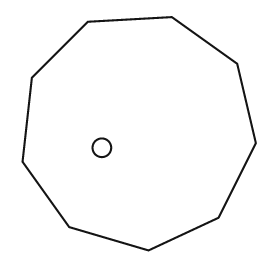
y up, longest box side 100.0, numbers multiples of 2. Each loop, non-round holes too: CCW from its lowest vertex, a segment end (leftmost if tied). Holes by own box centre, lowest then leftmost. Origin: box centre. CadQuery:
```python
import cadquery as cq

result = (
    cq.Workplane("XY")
    .moveTo(4.0, -50.0)
    .lineTo(34.0, -36.0)
    .lineTo(50.0, -4.0)
    .lineTo(42.0, 30.0)
    .lineTo(14.0, 50.0)
    .lineTo(-22.0, 48.0)
    .lineTo(-46.0, 24.0)
    .lineTo(-50.0, -12.0)
    .lineTo(-30.0, -40.0)
    .close()
    .moveTo(-16.0, -6.0)
    .circle(4.0)
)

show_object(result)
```